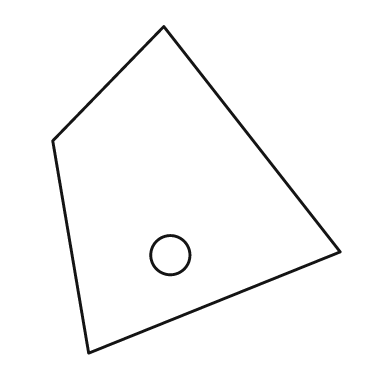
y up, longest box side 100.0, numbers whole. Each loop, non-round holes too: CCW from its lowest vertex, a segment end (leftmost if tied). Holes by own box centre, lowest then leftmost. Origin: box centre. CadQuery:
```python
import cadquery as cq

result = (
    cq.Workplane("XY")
    .moveTo(-33.0, -50.0)
    .lineTo(44.0, -19.0)
    .lineTo(-10.0, 50.0)
    .lineTo(-44.0, 15.0)
    .close()
    .moveTo(-8.0, -20.0)
    .circle(6.0)
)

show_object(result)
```